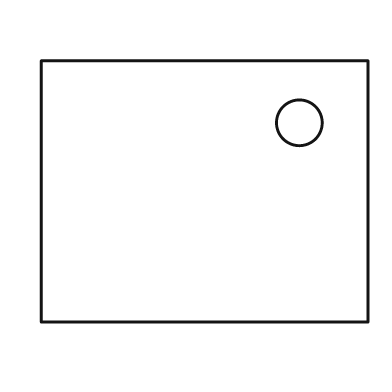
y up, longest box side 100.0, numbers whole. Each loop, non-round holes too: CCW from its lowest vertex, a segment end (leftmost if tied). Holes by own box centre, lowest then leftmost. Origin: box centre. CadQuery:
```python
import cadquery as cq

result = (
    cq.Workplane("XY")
    .moveTo(-50.0, -40.0)
    .lineTo(50.0, -40.0)
    .lineTo(50.0, 40.0)
    .lineTo(-50.0, 40.0)
    .close()
    .moveTo(29.0, 21.0)
    .circle(7.0)
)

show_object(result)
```